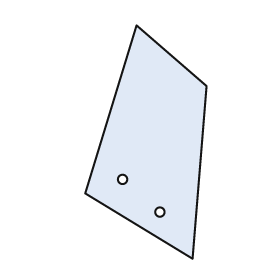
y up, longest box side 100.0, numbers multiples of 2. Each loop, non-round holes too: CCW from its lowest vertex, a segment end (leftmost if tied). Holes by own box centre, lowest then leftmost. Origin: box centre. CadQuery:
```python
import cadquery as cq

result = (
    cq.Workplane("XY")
    .moveTo(20.0, -50.0)
    .lineTo(26.0, 24.0)
    .lineTo(-4.0, 50.0)
    .lineTo(-26.0, -22.0)
    .close()
    .moveTo(6.0, -30.0)
    .circle(2.0)
    .moveTo(-10.0, -16.0)
    .circle(2.0)
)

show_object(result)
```